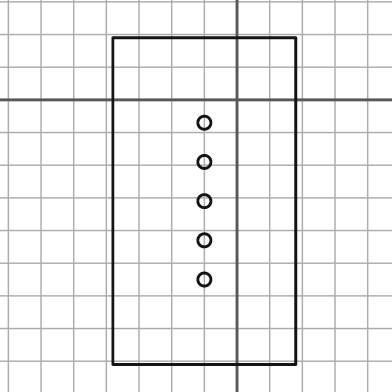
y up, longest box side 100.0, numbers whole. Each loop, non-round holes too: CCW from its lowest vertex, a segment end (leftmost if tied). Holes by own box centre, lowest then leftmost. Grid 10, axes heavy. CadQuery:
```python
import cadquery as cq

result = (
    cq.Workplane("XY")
    .moveTo(-38.0, -81.0)
    .lineTo(18.0, -81.0)
    .lineTo(18.0, 19.0)
    .lineTo(-38.0, 19.0)
    .close()
    .moveTo(-10.0, -55.0)
    .circle(2.0)
    .moveTo(-10.0, -43.0)
    .circle(2.0)
    .moveTo(-10.0, -31.0)
    .circle(2.0)
    .moveTo(-10.0, -19.0)
    .circle(2.0)
    .moveTo(-10.0, -7.0)
    .circle(2.0)
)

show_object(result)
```